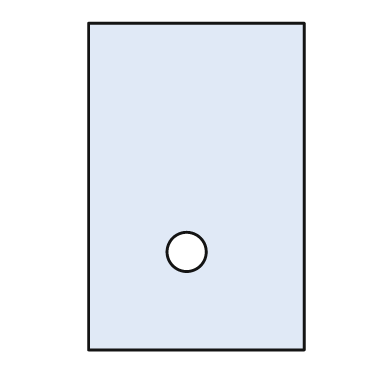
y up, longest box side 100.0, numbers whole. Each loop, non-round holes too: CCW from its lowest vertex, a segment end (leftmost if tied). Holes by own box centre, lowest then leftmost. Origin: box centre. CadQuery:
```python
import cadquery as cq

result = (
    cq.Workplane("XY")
    .moveTo(-33.0, -50.0)
    .lineTo(33.0, -50.0)
    .lineTo(33.0, 50.0)
    .lineTo(-33.0, 50.0)
    .close()
    .moveTo(-3.0, -20.0)
    .circle(6.0)
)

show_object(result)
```